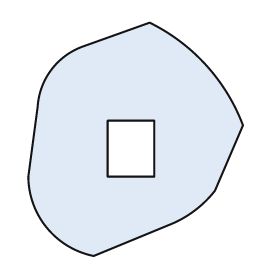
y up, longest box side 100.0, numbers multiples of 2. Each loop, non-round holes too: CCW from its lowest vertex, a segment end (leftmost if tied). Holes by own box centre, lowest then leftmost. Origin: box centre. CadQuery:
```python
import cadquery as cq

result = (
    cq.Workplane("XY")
    .moveTo(-18.0, -50.0)
    .lineTo(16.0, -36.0)
    .threePointArc((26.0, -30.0), (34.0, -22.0))
    .lineTo(46.0, 6.0)
    .threePointArc((30.0, 32.0), (6.0, 50.0))
    .lineTo(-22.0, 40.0)
    .threePointArc((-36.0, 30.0), (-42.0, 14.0))
    .lineTo(-46.0, -16.0)
    .threePointArc((-38.0, -38.0), (-18.0, -50.0))
    .close()
    .moveTo(-12.0, -16.0)
    .lineTo(8.0, -16.0)
    .lineTo(8.0, 8.0)
    .lineTo(-12.0, 8.0)
    .close()
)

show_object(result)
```